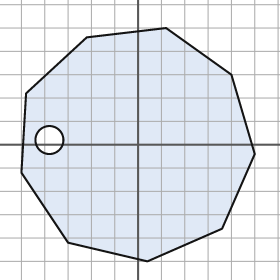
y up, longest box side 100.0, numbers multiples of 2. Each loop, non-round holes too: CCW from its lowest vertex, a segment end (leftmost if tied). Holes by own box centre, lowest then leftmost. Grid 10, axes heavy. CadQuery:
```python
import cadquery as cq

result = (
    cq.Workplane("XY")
    .moveTo(4.0, -50.0)
    .lineTo(36.0, -36.0)
    .lineTo(50.0, -4.0)
    .lineTo(40.0, 30.0)
    .lineTo(12.0, 50.0)
    .lineTo(-22.0, 46.0)
    .lineTo(-48.0, 22.0)
    .lineTo(-50.0, -12.0)
    .lineTo(-30.0, -42.0)
    .close()
    .moveTo(-38.0, 2.0)
    .circle(6.0)
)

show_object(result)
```